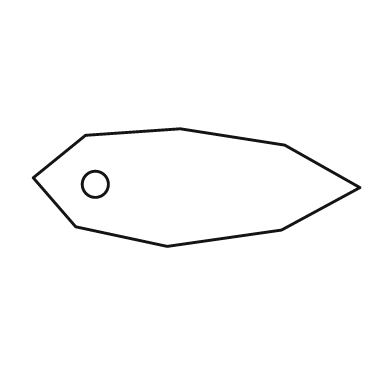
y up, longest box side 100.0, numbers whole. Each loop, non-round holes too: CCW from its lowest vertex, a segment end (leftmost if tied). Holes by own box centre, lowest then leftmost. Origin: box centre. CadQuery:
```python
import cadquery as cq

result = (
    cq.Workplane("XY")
    .moveTo(-9.0, -18.0)
    .lineTo(26.0, -13.0)
    .lineTo(50.0, 0.0)
    .lineTo(27.0, 13.0)
    .lineTo(-5.0, 18.0)
    .lineTo(-34.0, 16.0)
    .lineTo(-50.0, 3.0)
    .lineTo(-37.0, -12.0)
    .close()
    .moveTo(-31.0, 1.0)
    .circle(4.0)
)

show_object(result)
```